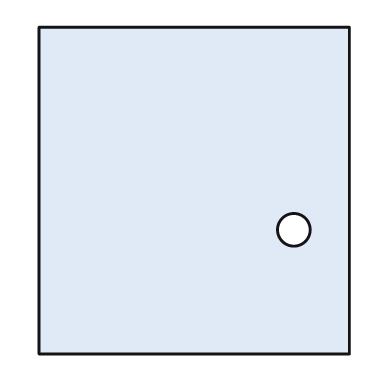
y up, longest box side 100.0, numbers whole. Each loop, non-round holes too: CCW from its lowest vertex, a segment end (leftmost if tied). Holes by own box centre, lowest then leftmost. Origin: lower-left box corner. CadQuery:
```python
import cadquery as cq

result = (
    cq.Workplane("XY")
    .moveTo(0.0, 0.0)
    .lineTo(95.0, 0.0)
    .lineTo(95.0, 100.0)
    .lineTo(0.0, 100.0)
    .close()
    .moveTo(78.0, 38.0)
    .circle(5.0)
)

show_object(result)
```